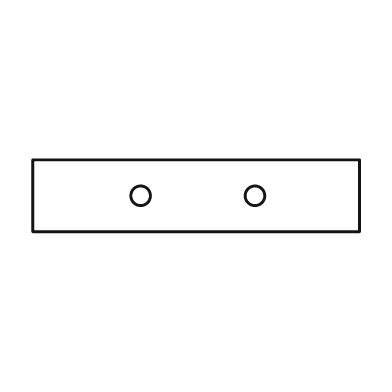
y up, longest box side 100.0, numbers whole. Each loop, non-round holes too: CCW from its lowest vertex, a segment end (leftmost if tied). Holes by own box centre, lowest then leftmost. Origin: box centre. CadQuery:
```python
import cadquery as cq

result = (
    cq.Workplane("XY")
    .moveTo(-50.0, -11.0)
    .lineTo(50.0, -11.0)
    .lineTo(50.0, 11.0)
    .lineTo(-50.0, 11.0)
    .close()
    .moveTo(-17.0, 0.0)
    .circle(3.0)
    .moveTo(18.0, 0.0)
    .circle(3.0)
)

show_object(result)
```